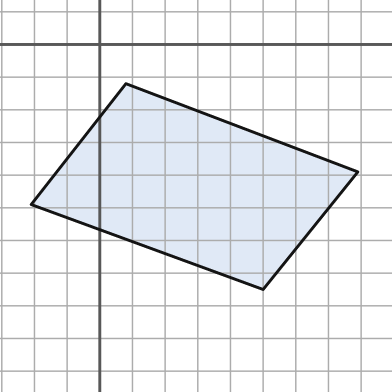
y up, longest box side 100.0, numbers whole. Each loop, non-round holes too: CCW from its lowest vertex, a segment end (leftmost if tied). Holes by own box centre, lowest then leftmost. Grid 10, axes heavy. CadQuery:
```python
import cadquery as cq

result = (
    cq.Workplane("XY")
    .moveTo(50.0, -75.0)
    .lineTo(79.0, -39.0)
    .lineTo(8.0, -12.0)
    .lineTo(-21.0, -49.0)
    .close()
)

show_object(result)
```